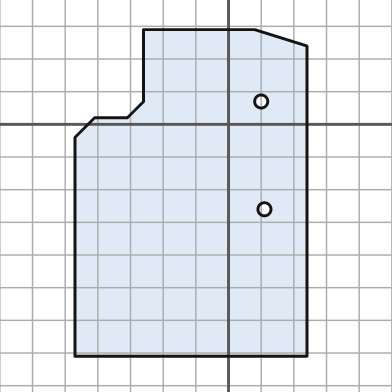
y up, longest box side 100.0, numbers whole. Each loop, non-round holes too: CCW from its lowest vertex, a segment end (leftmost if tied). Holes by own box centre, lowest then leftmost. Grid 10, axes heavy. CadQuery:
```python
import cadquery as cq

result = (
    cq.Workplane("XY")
    .moveTo(-47.0, -71.0)
    .lineTo(24.0, -71.0)
    .lineTo(24.0, 24.0)
    .lineTo(8.0, 29.0)
    .lineTo(-26.0, 29.0)
    .lineTo(-26.0, 7.0)
    .lineTo(-31.0, 2.0)
    .lineTo(-41.0, 2.0)
    .lineTo(-47.0, -4.0)
    .close()
    .moveTo(11.0, -26.0)
    .circle(2.0)
    .moveTo(10.0, 7.0)
    .circle(2.0)
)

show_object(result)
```